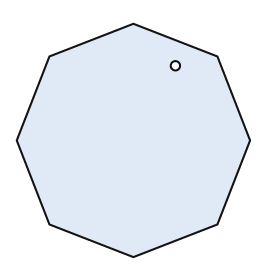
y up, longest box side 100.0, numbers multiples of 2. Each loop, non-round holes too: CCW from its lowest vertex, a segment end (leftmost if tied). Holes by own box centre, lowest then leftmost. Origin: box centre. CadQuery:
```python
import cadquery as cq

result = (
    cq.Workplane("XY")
    .moveTo(0.0, -50.0)
    .lineTo(36.0, -36.0)
    .lineTo(50.0, 0.0)
    .lineTo(36.0, 36.0)
    .lineTo(0.0, 50.0)
    .lineTo(-36.0, 36.0)
    .lineTo(-50.0, 0.0)
    .lineTo(-36.0, -36.0)
    .close()
    .moveTo(18.0, 32.0)
    .circle(2.0)
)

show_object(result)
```